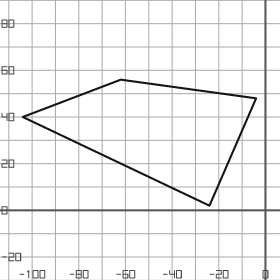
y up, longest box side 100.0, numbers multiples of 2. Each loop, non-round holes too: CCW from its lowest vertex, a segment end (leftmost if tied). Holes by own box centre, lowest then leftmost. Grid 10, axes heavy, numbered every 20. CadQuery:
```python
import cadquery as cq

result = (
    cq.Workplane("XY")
    .moveTo(-24.0, 2.0)
    .lineTo(-4.0, 48.0)
    .lineTo(-62.0, 56.0)
    .lineTo(-104.0, 40.0)
    .close()
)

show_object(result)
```